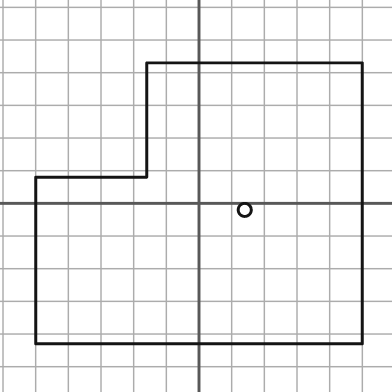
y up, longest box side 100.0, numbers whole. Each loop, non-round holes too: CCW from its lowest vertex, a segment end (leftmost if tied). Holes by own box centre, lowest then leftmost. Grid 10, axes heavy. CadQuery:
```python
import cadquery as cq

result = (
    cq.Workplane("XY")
    .moveTo(-50.0, -43.0)
    .lineTo(50.0, -43.0)
    .lineTo(50.0, 43.0)
    .lineTo(-16.0, 43.0)
    .lineTo(-16.0, 8.0)
    .lineTo(-50.0, 8.0)
    .close()
    .moveTo(14.0, -2.0)
    .circle(2.0)
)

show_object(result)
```